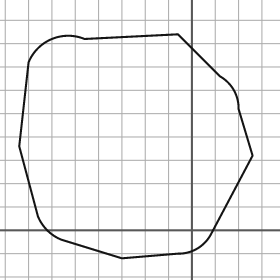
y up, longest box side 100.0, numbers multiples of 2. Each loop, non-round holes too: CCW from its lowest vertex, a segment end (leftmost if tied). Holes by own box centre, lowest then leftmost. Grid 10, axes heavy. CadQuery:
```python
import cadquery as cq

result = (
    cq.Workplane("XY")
    .moveTo(-30.0, -12.0)
    .lineTo(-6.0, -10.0)
    .threePointArc((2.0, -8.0), (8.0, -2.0))
    .lineTo(26.0, 32.0)
    .lineTo(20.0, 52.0)
    .threePointArc((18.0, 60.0), (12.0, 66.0))
    .lineTo(-6.0, 84.0)
    .lineTo(-46.0, 82.0)
    .threePointArc((-60.0, 82.0), (-70.0, 72.0))
    .lineTo(-74.0, 36.0)
    .lineTo(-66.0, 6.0)
    .threePointArc((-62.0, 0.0), (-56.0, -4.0))
    .close()
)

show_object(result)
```